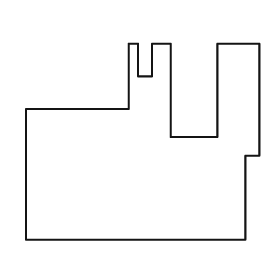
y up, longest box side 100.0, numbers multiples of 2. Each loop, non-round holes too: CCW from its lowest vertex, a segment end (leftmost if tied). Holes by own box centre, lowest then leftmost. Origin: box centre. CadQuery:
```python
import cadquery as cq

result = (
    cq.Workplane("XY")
    .moveTo(-50.0, -42.0)
    .lineTo(44.0, -42.0)
    .lineTo(44.0, -6.0)
    .lineTo(50.0, -6.0)
    .lineTo(50.0, 42.0)
    .lineTo(32.0, 42.0)
    .lineTo(32.0, 2.0)
    .lineTo(12.0, 2.0)
    .lineTo(12.0, 42.0)
    .lineTo(4.0, 42.0)
    .lineTo(4.0, 28.0)
    .lineTo(-2.0, 28.0)
    .lineTo(-2.0, 42.0)
    .lineTo(-6.0, 42.0)
    .lineTo(-6.0, 14.0)
    .lineTo(-50.0, 14.0)
    .close()
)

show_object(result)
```